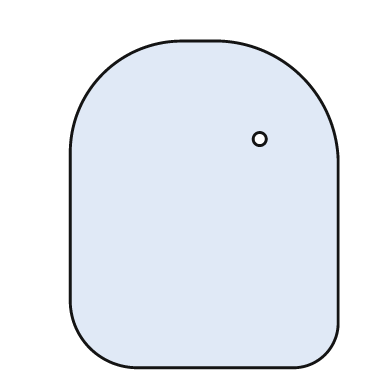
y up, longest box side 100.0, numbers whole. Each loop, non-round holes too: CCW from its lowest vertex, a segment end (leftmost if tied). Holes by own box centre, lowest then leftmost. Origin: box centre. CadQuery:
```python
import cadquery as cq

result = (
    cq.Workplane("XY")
    .moveTo(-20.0, -50.0)
    .lineTo(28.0, -50.0)
    .threePointArc((37.0, -46.0), (41.0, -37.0))
    .lineTo(41.0, 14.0)
    .threePointArc((30.0, 39.0), (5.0, 50.0))
    .lineTo(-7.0, 50.0)
    .threePointArc((-31.0, 40.0), (-41.0, 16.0))
    .lineTo(-41.0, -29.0)
    .threePointArc((-35.0, -44.0), (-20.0, -50.0))
    .close()
    .moveTo(17.0, 20.0)
    .circle(2.0)
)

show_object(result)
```